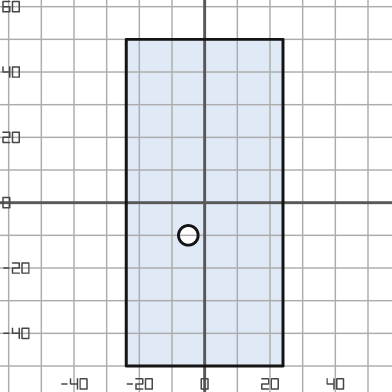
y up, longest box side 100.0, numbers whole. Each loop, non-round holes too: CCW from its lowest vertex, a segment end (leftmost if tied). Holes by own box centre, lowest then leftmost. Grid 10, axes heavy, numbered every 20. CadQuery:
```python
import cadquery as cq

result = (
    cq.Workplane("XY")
    .moveTo(-24.0, -50.0)
    .lineTo(24.0, -50.0)
    .lineTo(24.0, 50.0)
    .lineTo(-24.0, 50.0)
    .close()
    .moveTo(-5.0, -10.0)
    .circle(3.0)
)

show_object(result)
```